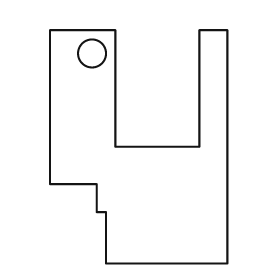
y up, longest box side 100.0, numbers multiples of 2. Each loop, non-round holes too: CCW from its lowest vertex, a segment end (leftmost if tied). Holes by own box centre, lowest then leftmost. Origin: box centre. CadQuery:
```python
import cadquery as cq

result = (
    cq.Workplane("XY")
    .moveTo(-14.0, -50.0)
    .lineTo(38.0, -50.0)
    .lineTo(38.0, 50.0)
    .lineTo(26.0, 50.0)
    .lineTo(26.0, 0.0)
    .lineTo(-10.0, 0.0)
    .lineTo(-10.0, 50.0)
    .lineTo(-38.0, 50.0)
    .lineTo(-38.0, -16.0)
    .lineTo(-18.0, -16.0)
    .lineTo(-18.0, -28.0)
    .lineTo(-14.0, -28.0)
    .close()
    .moveTo(-20.0, 40.0)
    .circle(6.0)
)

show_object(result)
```